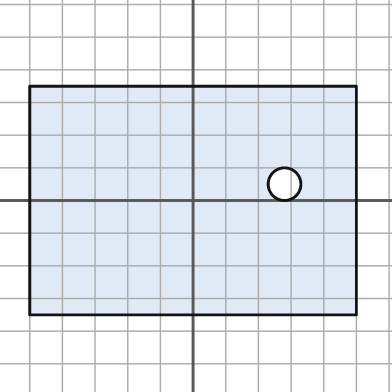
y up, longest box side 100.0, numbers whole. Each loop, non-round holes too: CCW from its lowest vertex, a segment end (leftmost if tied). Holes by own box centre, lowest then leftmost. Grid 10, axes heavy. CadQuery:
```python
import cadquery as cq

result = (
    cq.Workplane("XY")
    .moveTo(-50.0, -35.0)
    .lineTo(50.0, -35.0)
    .lineTo(50.0, 35.0)
    .lineTo(-50.0, 35.0)
    .close()
    .moveTo(28.0, 5.0)
    .circle(5.0)
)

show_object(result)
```